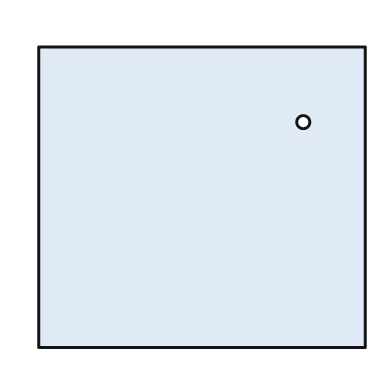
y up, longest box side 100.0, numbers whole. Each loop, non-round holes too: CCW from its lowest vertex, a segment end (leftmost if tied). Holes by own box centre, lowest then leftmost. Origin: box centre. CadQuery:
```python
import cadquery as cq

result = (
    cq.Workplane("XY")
    .moveTo(-50.0, -46.0)
    .lineTo(50.0, -46.0)
    .lineTo(50.0, 46.0)
    .lineTo(-50.0, 46.0)
    .close()
    .moveTo(31.0, 23.0)
    .circle(2.0)
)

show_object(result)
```